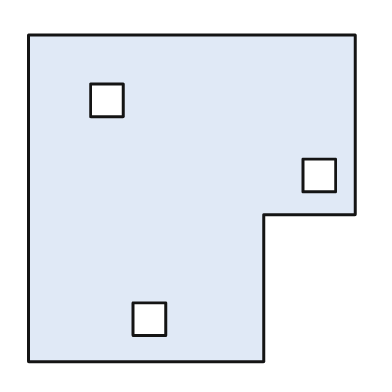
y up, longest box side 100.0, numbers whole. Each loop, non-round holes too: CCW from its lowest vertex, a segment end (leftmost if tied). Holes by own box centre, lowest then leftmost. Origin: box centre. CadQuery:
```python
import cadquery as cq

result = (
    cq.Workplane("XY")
    .moveTo(-50.0, -50.0)
    .lineTo(22.0, -50.0)
    .lineTo(22.0, -5.0)
    .lineTo(50.0, -5.0)
    .lineTo(50.0, 50.0)
    .lineTo(-50.0, 50.0)
    .close()
    .moveTo(-18.0, -42.0)
    .lineTo(-8.0, -42.0)
    .lineTo(-8.0, -32.0)
    .lineTo(-18.0, -32.0)
    .close()
    .moveTo(34.0, 2.0)
    .lineTo(44.0, 2.0)
    .lineTo(44.0, 12.0)
    .lineTo(34.0, 12.0)
    .close()
    .moveTo(-31.0, 25.0)
    .lineTo(-21.0, 25.0)
    .lineTo(-21.0, 35.0)
    .lineTo(-31.0, 35.0)
    .close()
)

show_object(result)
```